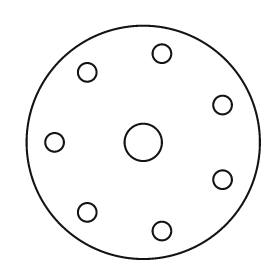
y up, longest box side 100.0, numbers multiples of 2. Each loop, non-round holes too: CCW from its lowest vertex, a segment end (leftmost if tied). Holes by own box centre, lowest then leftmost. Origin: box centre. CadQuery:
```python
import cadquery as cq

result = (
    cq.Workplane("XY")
    .moveTo(0.0, 0.0)
    .circle(50.0)
    .moveTo(8.0, -38.0)
    .circle(4.0)
    .moveTo(-24.0, -30.0)
    .circle(4.0)
    .moveTo(34.0, -16.0)
    .circle(4.0)
    .moveTo(-38.0, 0.0)
    .circle(4.0)
    .moveTo(0.0, 0.0)
    .circle(8.0)
    .moveTo(34.0, 16.0)
    .circle(4.0)
    .moveTo(-24.0, 30.0)
    .circle(4.0)
    .moveTo(8.0, 38.0)
    .circle(4.0)
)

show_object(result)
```